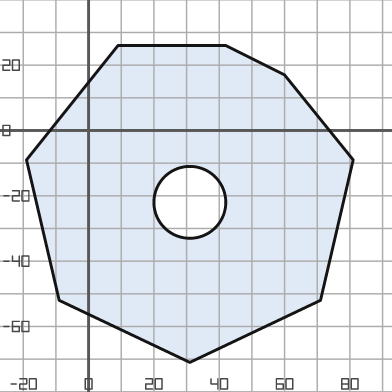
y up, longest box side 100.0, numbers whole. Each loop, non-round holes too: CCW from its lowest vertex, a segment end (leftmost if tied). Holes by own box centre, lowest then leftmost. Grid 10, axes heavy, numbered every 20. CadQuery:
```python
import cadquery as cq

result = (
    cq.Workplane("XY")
    .moveTo(31.0, -71.0)
    .lineTo(71.0, -52.0)
    .lineTo(81.0, -9.0)
    .lineTo(60.0, 17.0)
    .lineTo(42.0, 26.0)
    .lineTo(9.0, 26.0)
    .lineTo(-19.0, -9.0)
    .lineTo(-9.0, -52.0)
    .close()
    .moveTo(31.0, -22.0)
    .circle(11.0)
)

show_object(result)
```